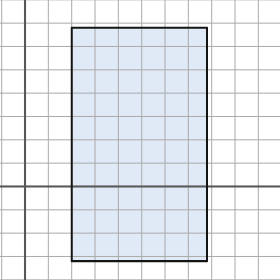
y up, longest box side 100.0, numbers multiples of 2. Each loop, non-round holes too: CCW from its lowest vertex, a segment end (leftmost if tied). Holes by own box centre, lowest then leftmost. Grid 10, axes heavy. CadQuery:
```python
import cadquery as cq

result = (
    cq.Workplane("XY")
    .moveTo(20.0, -32.0)
    .lineTo(78.0, -32.0)
    .lineTo(78.0, 68.0)
    .lineTo(20.0, 68.0)
    .close()
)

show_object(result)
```